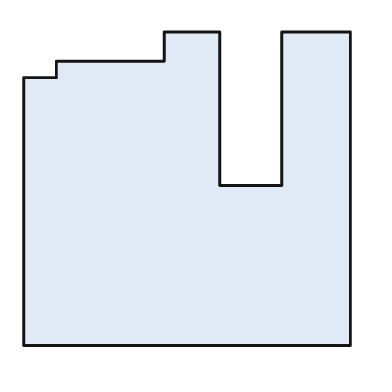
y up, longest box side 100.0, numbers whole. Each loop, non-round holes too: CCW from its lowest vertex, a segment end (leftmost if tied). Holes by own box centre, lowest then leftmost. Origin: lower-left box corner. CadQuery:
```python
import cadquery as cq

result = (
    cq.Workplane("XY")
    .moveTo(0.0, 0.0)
    .lineTo(100.0, 0.0)
    .lineTo(100.0, 96.0)
    .lineTo(79.0, 96.0)
    .lineTo(79.0, 49.0)
    .lineTo(60.0, 49.0)
    .lineTo(60.0, 96.0)
    .lineTo(43.0, 96.0)
    .lineTo(43.0, 87.0)
    .lineTo(10.0, 87.0)
    .lineTo(10.0, 82.0)
    .lineTo(0.0, 82.0)
    .close()
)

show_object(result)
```